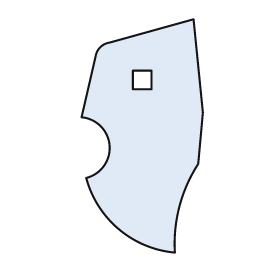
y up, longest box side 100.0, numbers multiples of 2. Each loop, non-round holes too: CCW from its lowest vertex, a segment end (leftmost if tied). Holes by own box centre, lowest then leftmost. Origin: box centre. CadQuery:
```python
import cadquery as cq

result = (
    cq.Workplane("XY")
    .moveTo(14.0, -50.0)
    .threePointArc((16.0, -30.0), (24.0, -12.0))
    .lineTo(26.0, 10.0)
    .lineTo(22.0, 50.0)
    .lineTo(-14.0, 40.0)
    .threePointArc((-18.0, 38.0), (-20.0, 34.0))
    .lineTo(-26.0, 8.0)
    .threePointArc((-14.0, -4.0), (-24.0, -18.0))
    .threePointArc((-10.0, -40.0), (14.0, -50.0))
    .close()
    .moveTo(-4.0, 20.0)
    .lineTo(4.0, 20.0)
    .lineTo(4.0, 28.0)
    .lineTo(-4.0, 28.0)
    .close()
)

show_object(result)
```